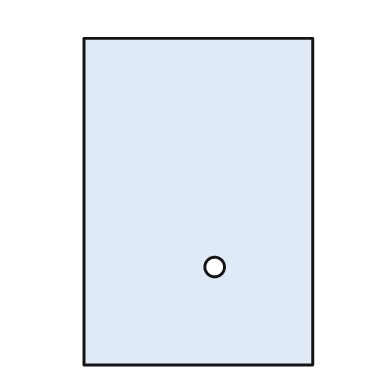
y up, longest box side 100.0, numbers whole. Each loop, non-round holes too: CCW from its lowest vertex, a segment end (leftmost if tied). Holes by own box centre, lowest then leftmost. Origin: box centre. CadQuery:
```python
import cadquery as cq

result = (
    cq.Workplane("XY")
    .moveTo(-35.0, -50.0)
    .lineTo(35.0, -50.0)
    .lineTo(35.0, 50.0)
    .lineTo(-35.0, 50.0)
    .close()
    .moveTo(5.0, -20.0)
    .circle(3.0)
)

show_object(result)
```